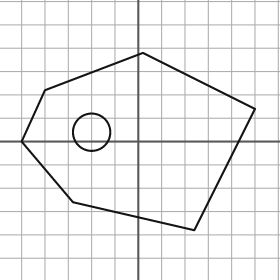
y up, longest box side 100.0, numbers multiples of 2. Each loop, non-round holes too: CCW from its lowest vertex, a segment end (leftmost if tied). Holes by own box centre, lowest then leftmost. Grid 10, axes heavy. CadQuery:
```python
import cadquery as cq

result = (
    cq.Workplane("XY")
    .moveTo(24.0, -38.0)
    .lineTo(50.0, 14.0)
    .lineTo(2.0, 38.0)
    .lineTo(-40.0, 22.0)
    .lineTo(-50.0, 0.0)
    .lineTo(-28.0, -26.0)
    .close()
    .moveTo(-20.0, 4.0)
    .circle(8.0)
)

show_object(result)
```